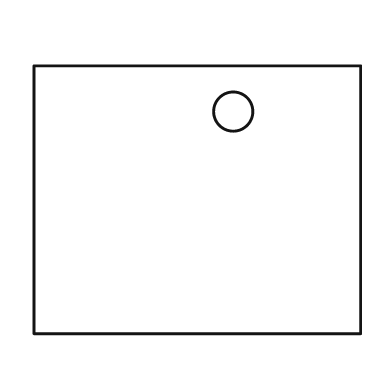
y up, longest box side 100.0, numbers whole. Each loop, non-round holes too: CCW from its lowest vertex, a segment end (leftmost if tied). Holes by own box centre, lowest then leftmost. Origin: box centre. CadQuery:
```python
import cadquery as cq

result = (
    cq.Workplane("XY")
    .moveTo(-50.0, -41.0)
    .lineTo(50.0, -41.0)
    .lineTo(50.0, 41.0)
    .lineTo(-50.0, 41.0)
    .close()
    .moveTo(11.0, 27.0)
    .circle(6.0)
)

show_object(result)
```